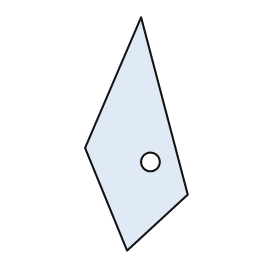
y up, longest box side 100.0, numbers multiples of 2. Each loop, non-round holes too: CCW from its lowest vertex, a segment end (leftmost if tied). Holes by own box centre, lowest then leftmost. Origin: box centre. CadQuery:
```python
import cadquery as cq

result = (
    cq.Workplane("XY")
    .moveTo(-4.0, -50.0)
    .lineTo(22.0, -26.0)
    .lineTo(2.0, 50.0)
    .lineTo(-22.0, -6.0)
    .close()
    .moveTo(6.0, -12.0)
    .circle(4.0)
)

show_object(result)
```